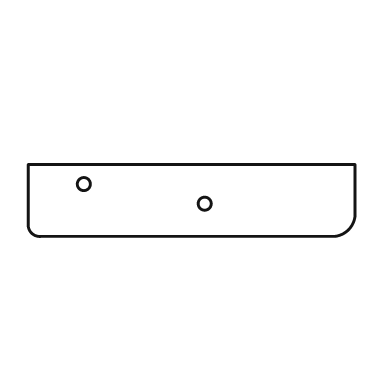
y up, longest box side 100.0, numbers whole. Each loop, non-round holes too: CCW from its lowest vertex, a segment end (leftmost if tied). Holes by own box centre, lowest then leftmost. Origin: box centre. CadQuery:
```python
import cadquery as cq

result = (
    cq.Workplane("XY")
    .moveTo(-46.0, -11.0)
    .lineTo(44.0, -11.0)
    .threePointArc((48.0, -9.0), (50.0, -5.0))
    .lineTo(50.0, 11.0)
    .lineTo(-50.0, 11.0)
    .lineTo(-50.0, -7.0)
    .threePointArc((-49.0, -10.0), (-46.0, -11.0))
    .close()
    .moveTo(4.0, -1.0)
    .circle(2.0)
    .moveTo(-33.0, 5.0)
    .circle(2.0)
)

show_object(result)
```